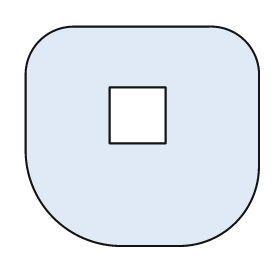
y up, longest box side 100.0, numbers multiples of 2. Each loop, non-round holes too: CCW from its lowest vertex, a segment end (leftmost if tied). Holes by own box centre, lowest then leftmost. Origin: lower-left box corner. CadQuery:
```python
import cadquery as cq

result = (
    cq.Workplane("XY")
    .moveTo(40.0, 0.0)
    .lineTo(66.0, 0.0)
    .threePointArc((90.0, 10.0), (100.0, 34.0))
    .lineTo(100.0, 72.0)
    .threePointArc((94.0, 88.0), (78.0, 94.0))
    .lineTo(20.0, 94.0)
    .threePointArc((6.0, 88.0), (0.0, 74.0))
    .lineTo(0.0, 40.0)
    .threePointArc((12.0, 12.0), (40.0, 0.0))
    .close()
    .moveTo(36.0, 44.0)
    .lineTo(60.0, 44.0)
    .lineTo(60.0, 68.0)
    .lineTo(36.0, 68.0)
    .close()
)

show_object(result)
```